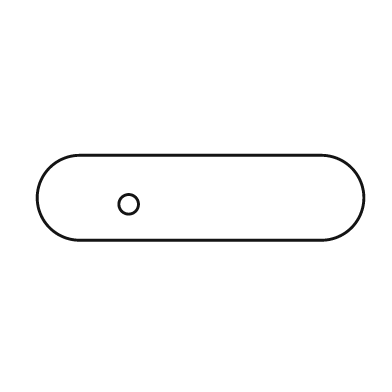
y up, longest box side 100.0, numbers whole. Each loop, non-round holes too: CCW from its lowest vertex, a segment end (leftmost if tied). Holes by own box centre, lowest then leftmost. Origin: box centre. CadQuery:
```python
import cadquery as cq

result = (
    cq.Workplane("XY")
    .moveTo(-37.0, -13.0)
    .lineTo(37.0, -13.0)
    .threePointArc((50.0, 0.0), (37.0, 13.0))
    .lineTo(-37.0, 13.0)
    .threePointArc((-50.0, 0.0), (-37.0, -13.0))
    .close()
    .moveTo(-22.0, -2.0)
    .circle(3.0)
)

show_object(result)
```